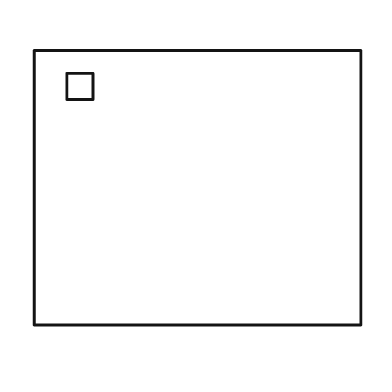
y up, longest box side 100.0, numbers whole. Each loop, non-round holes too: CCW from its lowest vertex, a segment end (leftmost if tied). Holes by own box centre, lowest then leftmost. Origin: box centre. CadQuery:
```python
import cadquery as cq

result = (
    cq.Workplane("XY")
    .moveTo(-50.0, -42.0)
    .lineTo(50.0, -42.0)
    .lineTo(50.0, 42.0)
    .lineTo(-50.0, 42.0)
    .close()
    .moveTo(-40.0, 27.0)
    .lineTo(-32.0, 27.0)
    .lineTo(-32.0, 35.0)
    .lineTo(-40.0, 35.0)
    .close()
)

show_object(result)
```